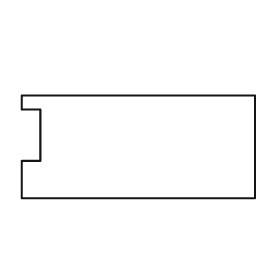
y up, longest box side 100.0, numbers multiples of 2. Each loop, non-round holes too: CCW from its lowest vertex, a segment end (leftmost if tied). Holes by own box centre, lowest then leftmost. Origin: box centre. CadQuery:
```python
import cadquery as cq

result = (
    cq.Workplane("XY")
    .moveTo(-50.0, -22.0)
    .lineTo(50.0, -22.0)
    .lineTo(50.0, 22.0)
    .lineTo(-50.0, 22.0)
    .lineTo(-50.0, 16.0)
    .lineTo(-42.0, 16.0)
    .lineTo(-42.0, -6.0)
    .lineTo(-50.0, -6.0)
    .close()
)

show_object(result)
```